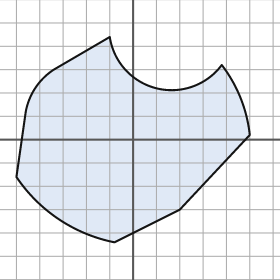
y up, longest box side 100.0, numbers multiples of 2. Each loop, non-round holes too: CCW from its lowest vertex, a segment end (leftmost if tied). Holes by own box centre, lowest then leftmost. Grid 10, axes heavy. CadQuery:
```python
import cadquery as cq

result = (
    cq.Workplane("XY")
    .moveTo(-8.0, -44.0)
    .lineTo(20.0, -30.0)
    .lineTo(50.0, 2.0)
    .threePointArc((46.0, 18.0), (38.0, 32.0))
    .threePointArc((10.0, 22.0), (-10.0, 44.0))
    .lineTo(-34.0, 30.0)
    .threePointArc((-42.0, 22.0), (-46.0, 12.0))
    .lineTo(-50.0, -16.0)
    .threePointArc((-32.0, -34.0), (-8.0, -44.0))
    .close()
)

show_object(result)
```